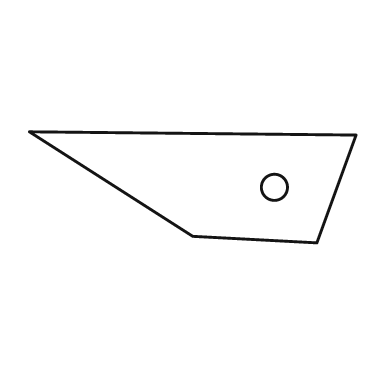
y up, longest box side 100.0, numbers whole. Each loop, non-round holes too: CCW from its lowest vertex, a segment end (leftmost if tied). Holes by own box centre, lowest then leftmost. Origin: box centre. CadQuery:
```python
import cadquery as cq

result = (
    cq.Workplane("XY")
    .moveTo(38.0, -17.0)
    .lineTo(50.0, 16.0)
    .lineTo(-50.0, 17.0)
    .lineTo(0.0, -15.0)
    .close()
    .moveTo(25.0, 0.0)
    .circle(4.0)
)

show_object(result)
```